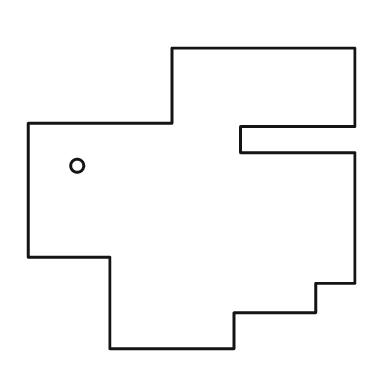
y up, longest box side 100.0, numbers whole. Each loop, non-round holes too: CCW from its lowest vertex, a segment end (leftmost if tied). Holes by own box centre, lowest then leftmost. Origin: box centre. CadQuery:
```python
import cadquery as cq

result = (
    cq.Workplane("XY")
    .moveTo(-25.0, -46.0)
    .lineTo(13.0, -46.0)
    .lineTo(13.0, -35.0)
    .lineTo(38.0, -35.0)
    .lineTo(38.0, -26.0)
    .lineTo(50.0, -26.0)
    .lineTo(50.0, 14.0)
    .lineTo(15.0, 14.0)
    .lineTo(15.0, 22.0)
    .lineTo(50.0, 22.0)
    .lineTo(50.0, 46.0)
    .lineTo(-6.0, 46.0)
    .lineTo(-6.0, 23.0)
    .lineTo(-50.0, 23.0)
    .lineTo(-50.0, -18.0)
    .lineTo(-25.0, -18.0)
    .close()
    .moveTo(-35.0, 10.0)
    .circle(2.0)
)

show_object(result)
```